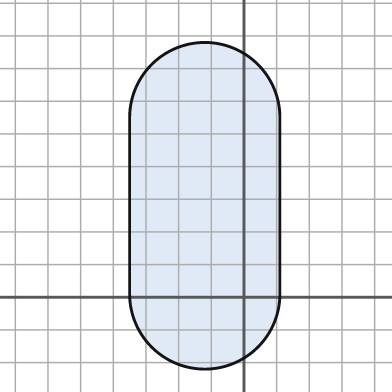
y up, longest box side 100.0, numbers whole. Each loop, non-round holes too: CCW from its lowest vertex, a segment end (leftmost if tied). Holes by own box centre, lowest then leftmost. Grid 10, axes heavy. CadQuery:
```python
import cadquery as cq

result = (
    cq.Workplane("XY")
    .moveTo(-35.0, 1.0)
    .threePointArc((-12.0, -22.0), (11.0, 1.0))
    .lineTo(11.0, 55.0)
    .threePointArc((-12.0, 78.0), (-35.0, 55.0))
    .close()
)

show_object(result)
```